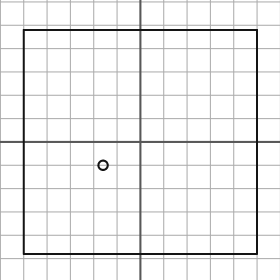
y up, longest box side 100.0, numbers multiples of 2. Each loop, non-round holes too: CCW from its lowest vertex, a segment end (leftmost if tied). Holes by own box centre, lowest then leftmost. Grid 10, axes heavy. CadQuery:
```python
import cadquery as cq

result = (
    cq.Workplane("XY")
    .moveTo(-50.0, -48.0)
    .lineTo(50.0, -48.0)
    .lineTo(50.0, 48.0)
    .lineTo(-50.0, 48.0)
    .close()
    .moveTo(-16.0, -10.0)
    .circle(2.0)
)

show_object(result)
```